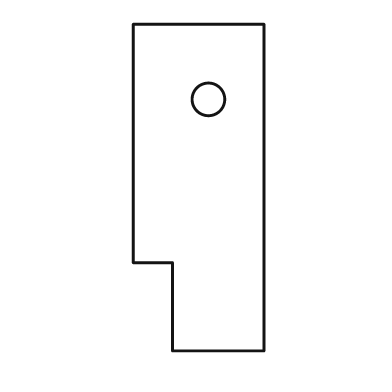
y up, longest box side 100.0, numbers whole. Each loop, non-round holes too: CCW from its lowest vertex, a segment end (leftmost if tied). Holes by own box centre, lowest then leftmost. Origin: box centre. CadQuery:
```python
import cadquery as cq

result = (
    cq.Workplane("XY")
    .moveTo(-8.0, -50.0)
    .lineTo(20.0, -50.0)
    .lineTo(20.0, 50.0)
    .lineTo(-20.0, 50.0)
    .lineTo(-20.0, -23.0)
    .lineTo(-8.0, -23.0)
    .close()
    .moveTo(3.0, 27.0)
    .circle(5.0)
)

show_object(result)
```